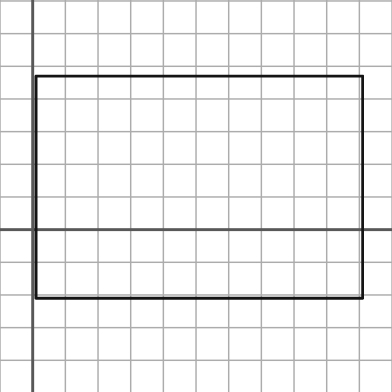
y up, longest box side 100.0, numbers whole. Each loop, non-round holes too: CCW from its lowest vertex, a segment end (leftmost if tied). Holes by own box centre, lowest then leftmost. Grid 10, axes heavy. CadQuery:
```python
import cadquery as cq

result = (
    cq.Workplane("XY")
    .moveTo(1.0, -21.0)
    .lineTo(101.0, -21.0)
    .lineTo(101.0, 47.0)
    .lineTo(1.0, 47.0)
    .close()
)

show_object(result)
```